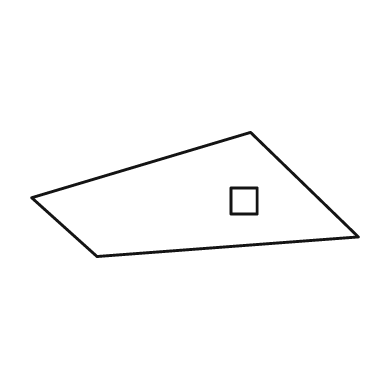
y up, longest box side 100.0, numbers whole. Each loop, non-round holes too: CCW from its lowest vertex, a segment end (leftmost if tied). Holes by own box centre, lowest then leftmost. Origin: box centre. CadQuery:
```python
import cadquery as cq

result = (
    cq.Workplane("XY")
    .moveTo(-30.0, -19.0)
    .lineTo(50.0, -13.0)
    .lineTo(17.0, 19.0)
    .lineTo(-50.0, -1.0)
    .close()
    .moveTo(11.0, -6.0)
    .lineTo(19.0, -6.0)
    .lineTo(19.0, 2.0)
    .lineTo(11.0, 2.0)
    .close()
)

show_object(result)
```